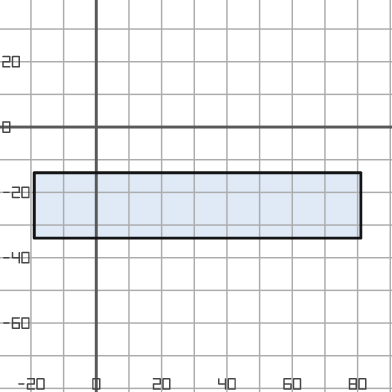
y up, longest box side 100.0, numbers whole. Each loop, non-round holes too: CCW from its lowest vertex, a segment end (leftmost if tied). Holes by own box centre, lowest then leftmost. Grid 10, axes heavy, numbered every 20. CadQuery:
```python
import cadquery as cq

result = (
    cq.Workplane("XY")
    .moveTo(-19.0, -34.0)
    .lineTo(81.0, -34.0)
    .lineTo(81.0, -14.0)
    .lineTo(-19.0, -14.0)
    .close()
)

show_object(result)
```